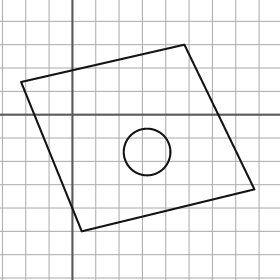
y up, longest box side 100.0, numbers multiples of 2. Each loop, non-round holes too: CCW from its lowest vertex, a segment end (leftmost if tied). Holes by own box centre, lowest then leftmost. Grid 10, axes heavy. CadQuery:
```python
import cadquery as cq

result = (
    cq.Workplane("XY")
    .moveTo(4.0, -50.0)
    .lineTo(78.0, -32.0)
    .lineTo(48.0, 30.0)
    .lineTo(-22.0, 14.0)
    .close()
    .moveTo(32.0, -16.0)
    .circle(10.0)
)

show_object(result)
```